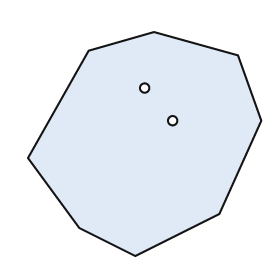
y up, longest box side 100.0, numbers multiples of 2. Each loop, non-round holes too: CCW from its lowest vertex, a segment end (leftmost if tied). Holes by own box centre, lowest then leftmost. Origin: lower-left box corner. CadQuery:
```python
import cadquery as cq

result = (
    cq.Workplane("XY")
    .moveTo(46.0, 0.0)
    .lineTo(82.0, 18.0)
    .lineTo(100.0, 58.0)
    .lineTo(90.0, 86.0)
    .lineTo(54.0, 96.0)
    .lineTo(26.0, 88.0)
    .lineTo(0.0, 42.0)
    .lineTo(22.0, 12.0)
    .close()
    .moveTo(62.0, 58.0)
    .circle(2.0)
    .moveTo(50.0, 72.0)
    .circle(2.0)
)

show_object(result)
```